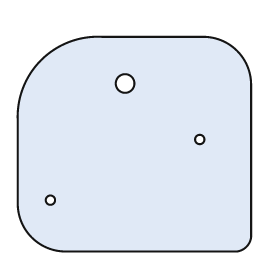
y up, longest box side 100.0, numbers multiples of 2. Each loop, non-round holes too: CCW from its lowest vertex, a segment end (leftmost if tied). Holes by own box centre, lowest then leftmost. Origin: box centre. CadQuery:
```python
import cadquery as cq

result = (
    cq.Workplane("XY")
    .moveTo(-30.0, -46.0)
    .lineTo(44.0, -46.0)
    .threePointArc((48.0, -44.0), (50.0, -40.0))
    .lineTo(50.0, 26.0)
    .threePointArc((44.0, 40.0), (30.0, 46.0))
    .lineTo(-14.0, 46.0)
    .threePointArc((-40.0, 36.0), (-50.0, 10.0))
    .lineTo(-50.0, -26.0)
    .threePointArc((-44.0, -40.0), (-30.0, -46.0))
    .close()
    .moveTo(-36.0, -24.0)
    .circle(2.0)
    .moveTo(28.0, 2.0)
    .circle(2.0)
    .moveTo(-4.0, 26.0)
    .circle(4.0)
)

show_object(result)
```